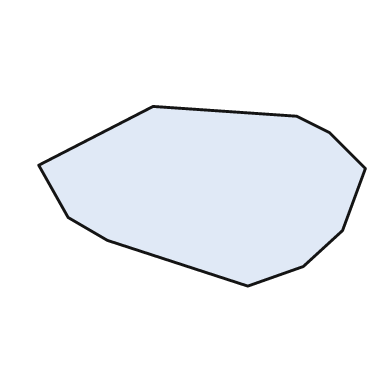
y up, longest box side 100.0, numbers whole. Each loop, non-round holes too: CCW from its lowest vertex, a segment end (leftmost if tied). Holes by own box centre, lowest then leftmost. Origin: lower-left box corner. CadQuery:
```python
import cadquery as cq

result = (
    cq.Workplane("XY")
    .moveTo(64.0, 0.0)
    .lineTo(81.0, 6.0)
    .lineTo(93.0, 17.0)
    .lineTo(100.0, 36.0)
    .lineTo(89.0, 47.0)
    .lineTo(79.0, 52.0)
    .lineTo(35.0, 55.0)
    .lineTo(0.0, 37.0)
    .lineTo(9.0, 21.0)
    .lineTo(21.0, 14.0)
    .close()
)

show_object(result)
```